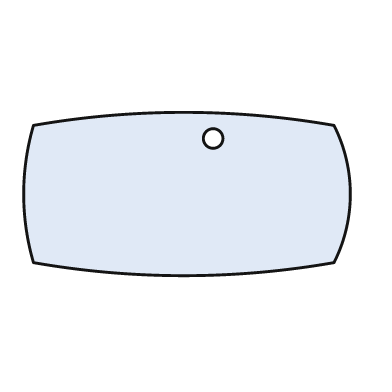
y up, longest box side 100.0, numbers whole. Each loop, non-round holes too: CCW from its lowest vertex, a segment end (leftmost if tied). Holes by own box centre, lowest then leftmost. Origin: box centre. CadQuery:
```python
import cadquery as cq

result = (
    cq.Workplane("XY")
    .moveTo(-47.0, -21.0)
    .threePointArc((-1.0, -25.0), (45.0, -21.0))
    .threePointArc((50.0, 0.0), (45.0, 21.0))
    .threePointArc((-1.0, 25.0), (-47.0, 21.0))
    .threePointArc((-50.0, 0.0), (-47.0, -21.0))
    .close()
    .moveTo(8.0, 17.0)
    .circle(3.0)
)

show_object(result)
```